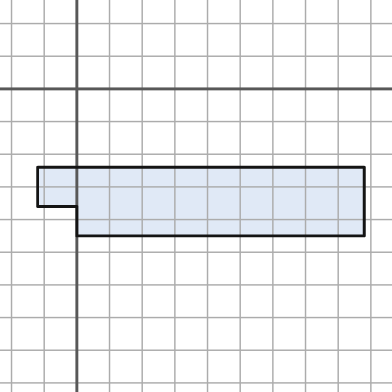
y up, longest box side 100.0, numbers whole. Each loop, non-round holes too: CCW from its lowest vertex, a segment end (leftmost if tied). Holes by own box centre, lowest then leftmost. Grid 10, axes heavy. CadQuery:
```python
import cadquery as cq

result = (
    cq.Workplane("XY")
    .moveTo(0.0, -45.0)
    .lineTo(88.0, -45.0)
    .lineTo(88.0, -24.0)
    .lineTo(-12.0, -24.0)
    .lineTo(-12.0, -36.0)
    .lineTo(0.0, -36.0)
    .close()
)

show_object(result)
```